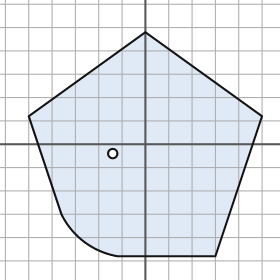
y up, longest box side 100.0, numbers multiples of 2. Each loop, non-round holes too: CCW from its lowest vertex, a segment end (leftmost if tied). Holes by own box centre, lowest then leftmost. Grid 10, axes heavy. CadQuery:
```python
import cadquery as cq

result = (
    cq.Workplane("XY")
    .moveTo(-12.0, -48.0)
    .lineTo(30.0, -48.0)
    .lineTo(50.0, 12.0)
    .lineTo(0.0, 48.0)
    .lineTo(-50.0, 12.0)
    .lineTo(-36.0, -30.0)
    .threePointArc((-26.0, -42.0), (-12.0, -48.0))
    .close()
    .moveTo(-14.0, -4.0)
    .circle(2.0)
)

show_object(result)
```